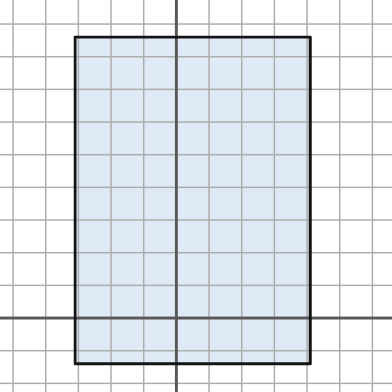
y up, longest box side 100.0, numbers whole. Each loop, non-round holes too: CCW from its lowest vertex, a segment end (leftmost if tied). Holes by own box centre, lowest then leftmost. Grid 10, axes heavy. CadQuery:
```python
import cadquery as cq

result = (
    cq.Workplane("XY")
    .moveTo(-31.0, -14.0)
    .lineTo(41.0, -14.0)
    .lineTo(41.0, 86.0)
    .lineTo(-31.0, 86.0)
    .close()
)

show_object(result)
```